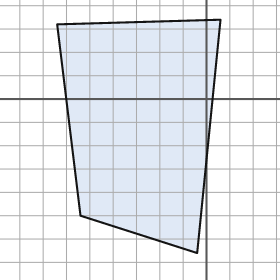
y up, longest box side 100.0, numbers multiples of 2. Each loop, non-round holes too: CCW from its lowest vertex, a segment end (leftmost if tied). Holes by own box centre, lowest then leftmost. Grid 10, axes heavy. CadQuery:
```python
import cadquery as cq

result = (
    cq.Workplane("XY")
    .moveTo(-4.0, -66.0)
    .lineTo(6.0, 34.0)
    .lineTo(-64.0, 32.0)
    .lineTo(-54.0, -50.0)
    .close()
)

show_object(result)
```